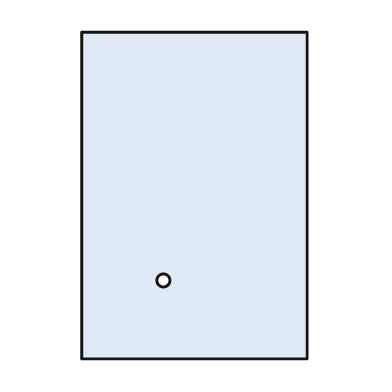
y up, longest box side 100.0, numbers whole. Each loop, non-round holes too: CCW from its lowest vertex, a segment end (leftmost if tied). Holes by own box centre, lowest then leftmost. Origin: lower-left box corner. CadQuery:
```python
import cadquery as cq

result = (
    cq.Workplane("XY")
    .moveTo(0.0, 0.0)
    .lineTo(69.0, 0.0)
    .lineTo(69.0, 100.0)
    .lineTo(0.0, 100.0)
    .close()
    .moveTo(25.0, 24.0)
    .circle(2.0)
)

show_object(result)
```